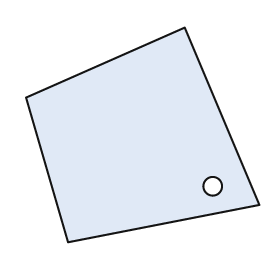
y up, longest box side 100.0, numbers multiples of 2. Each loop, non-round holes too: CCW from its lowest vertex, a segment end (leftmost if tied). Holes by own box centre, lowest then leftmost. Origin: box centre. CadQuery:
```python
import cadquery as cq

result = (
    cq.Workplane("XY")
    .moveTo(-32.0, -46.0)
    .lineTo(50.0, -30.0)
    .lineTo(18.0, 46.0)
    .lineTo(-50.0, 16.0)
    .close()
    .moveTo(30.0, -22.0)
    .circle(4.0)
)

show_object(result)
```